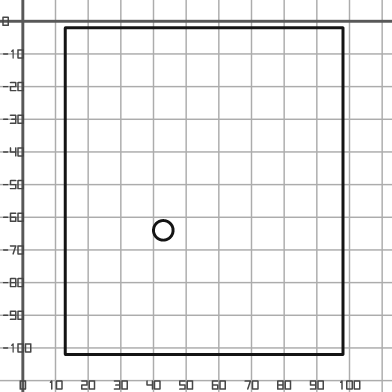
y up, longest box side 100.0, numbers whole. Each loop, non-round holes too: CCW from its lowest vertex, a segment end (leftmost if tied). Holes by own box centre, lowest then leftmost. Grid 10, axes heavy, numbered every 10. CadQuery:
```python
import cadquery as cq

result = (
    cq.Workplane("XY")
    .moveTo(13.0, -102.0)
    .lineTo(98.0, -102.0)
    .lineTo(98.0, -2.0)
    .lineTo(13.0, -2.0)
    .close()
    .moveTo(43.0, -64.0)
    .circle(3.0)
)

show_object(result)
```